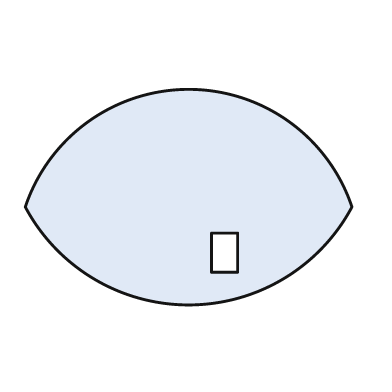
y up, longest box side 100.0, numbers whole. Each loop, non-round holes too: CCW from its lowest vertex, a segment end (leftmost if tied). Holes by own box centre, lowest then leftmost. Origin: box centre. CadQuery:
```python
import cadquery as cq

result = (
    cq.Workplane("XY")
    .moveTo(-50.0, -3.0)
    .threePointArc((0.0, -33.0), (50.0, -3.0))
    .threePointArc((0.0, 33.0), (-50.0, -3.0))
    .close()
    .moveTo(7.0, -23.0)
    .lineTo(15.0, -23.0)
    .lineTo(15.0, -11.0)
    .lineTo(7.0, -11.0)
    .close()
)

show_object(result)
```